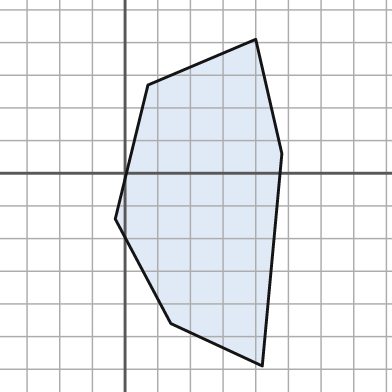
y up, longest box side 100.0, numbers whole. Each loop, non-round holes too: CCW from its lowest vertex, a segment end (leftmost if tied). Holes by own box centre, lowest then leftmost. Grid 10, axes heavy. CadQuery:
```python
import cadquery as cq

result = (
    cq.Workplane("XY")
    .moveTo(42.0, -59.0)
    .lineTo(48.0, 6.0)
    .lineTo(40.0, 41.0)
    .lineTo(7.0, 27.0)
    .lineTo(-3.0, -14.0)
    .lineTo(14.0, -46.0)
    .close()
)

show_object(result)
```